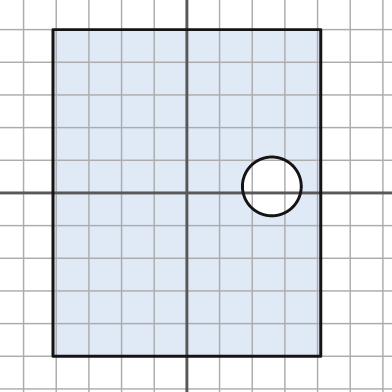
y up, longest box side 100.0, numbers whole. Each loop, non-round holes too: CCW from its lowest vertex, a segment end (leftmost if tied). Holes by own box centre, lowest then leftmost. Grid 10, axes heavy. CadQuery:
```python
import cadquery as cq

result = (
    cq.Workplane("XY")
    .moveTo(-41.0, -50.0)
    .lineTo(41.0, -50.0)
    .lineTo(41.0, 50.0)
    .lineTo(-41.0, 50.0)
    .close()
    .moveTo(26.0, 2.0)
    .circle(9.0)
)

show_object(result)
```